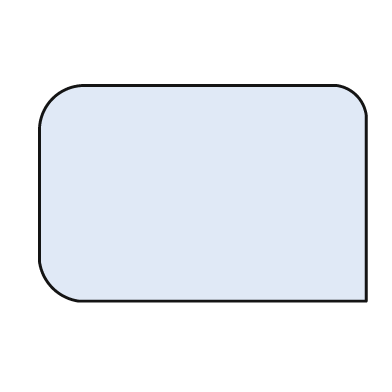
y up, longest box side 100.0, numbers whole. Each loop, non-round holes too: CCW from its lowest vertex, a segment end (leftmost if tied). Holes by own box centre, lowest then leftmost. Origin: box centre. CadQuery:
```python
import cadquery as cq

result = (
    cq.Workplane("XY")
    .moveTo(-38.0, -33.0)
    .lineTo(50.0, -33.0)
    .lineTo(50.0, 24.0)
    .threePointArc((47.0, 30.0), (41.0, 33.0))
    .lineTo(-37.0, 33.0)
    .threePointArc((-46.0, 29.0), (-50.0, 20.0))
    .lineTo(-50.0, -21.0)
    .threePointArc((-46.0, -29.0), (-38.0, -33.0))
    .close()
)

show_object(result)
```